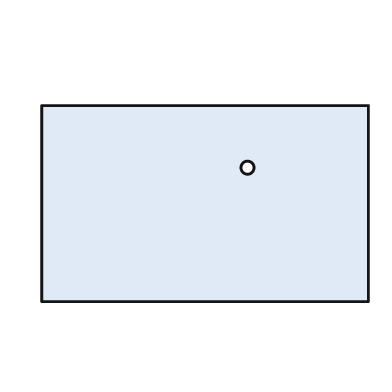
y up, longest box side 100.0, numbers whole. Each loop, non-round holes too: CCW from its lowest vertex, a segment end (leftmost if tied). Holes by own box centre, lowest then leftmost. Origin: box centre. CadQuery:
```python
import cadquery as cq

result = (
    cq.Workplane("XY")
    .moveTo(-50.0, -30.0)
    .lineTo(50.0, -30.0)
    .lineTo(50.0, 30.0)
    .lineTo(-50.0, 30.0)
    .close()
    .moveTo(13.0, 11.0)
    .circle(2.0)
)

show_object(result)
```